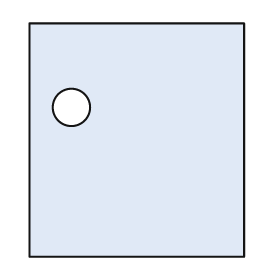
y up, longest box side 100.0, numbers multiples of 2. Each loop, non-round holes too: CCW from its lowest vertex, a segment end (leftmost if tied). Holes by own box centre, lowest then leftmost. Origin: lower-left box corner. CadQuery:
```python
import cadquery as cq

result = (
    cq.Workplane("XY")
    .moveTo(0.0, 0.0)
    .lineTo(92.0, 0.0)
    .lineTo(92.0, 100.0)
    .lineTo(0.0, 100.0)
    .close()
    .moveTo(18.0, 64.0)
    .circle(8.0)
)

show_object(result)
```